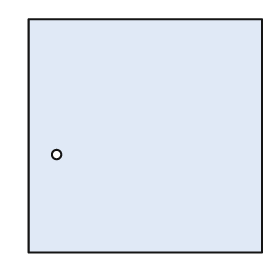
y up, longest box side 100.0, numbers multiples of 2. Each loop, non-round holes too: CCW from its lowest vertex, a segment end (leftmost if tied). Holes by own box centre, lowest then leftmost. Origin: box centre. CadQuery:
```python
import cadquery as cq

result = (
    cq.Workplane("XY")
    .moveTo(-50.0, -50.0)
    .lineTo(50.0, -50.0)
    .lineTo(50.0, 50.0)
    .lineTo(-50.0, 50.0)
    .close()
    .moveTo(-38.0, -8.0)
    .circle(2.0)
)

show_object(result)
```